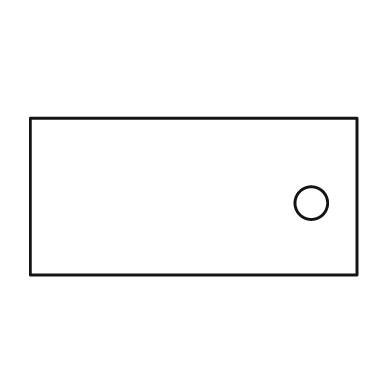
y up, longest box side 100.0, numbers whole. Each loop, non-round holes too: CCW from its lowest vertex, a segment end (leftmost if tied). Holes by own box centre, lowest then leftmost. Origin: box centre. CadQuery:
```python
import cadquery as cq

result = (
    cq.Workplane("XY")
    .moveTo(-50.0, -24.0)
    .lineTo(50.0, -24.0)
    .lineTo(50.0, 24.0)
    .lineTo(-50.0, 24.0)
    .close()
    .moveTo(36.0, -2.0)
    .circle(5.0)
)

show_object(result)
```